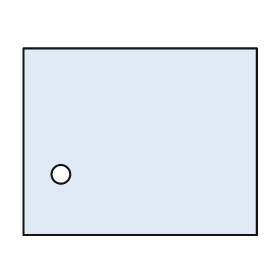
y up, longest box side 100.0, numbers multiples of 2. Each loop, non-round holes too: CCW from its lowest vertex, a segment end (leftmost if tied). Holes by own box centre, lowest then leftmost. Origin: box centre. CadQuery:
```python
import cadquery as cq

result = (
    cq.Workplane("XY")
    .moveTo(-50.0, -40.0)
    .lineTo(50.0, -40.0)
    .lineTo(50.0, 40.0)
    .lineTo(-50.0, 40.0)
    .close()
    .moveTo(-34.0, -14.0)
    .circle(4.0)
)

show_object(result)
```